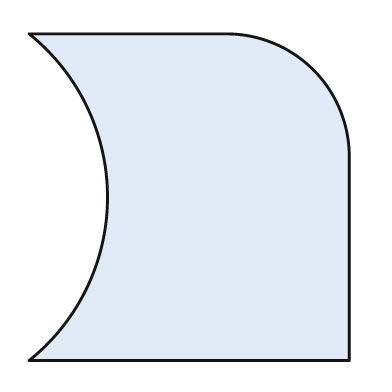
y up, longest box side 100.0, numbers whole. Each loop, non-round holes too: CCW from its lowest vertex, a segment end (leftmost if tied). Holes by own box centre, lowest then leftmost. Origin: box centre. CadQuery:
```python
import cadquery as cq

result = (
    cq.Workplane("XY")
    .moveTo(-49.0, -50.0)
    .lineTo(49.0, -50.0)
    .lineTo(49.0, 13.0)
    .threePointArc((38.0, 39.0), (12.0, 50.0))
    .lineTo(-49.0, 50.0)
    .threePointArc((-25.0, 0.0), (-49.0, -50.0))
    .close()
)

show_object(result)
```